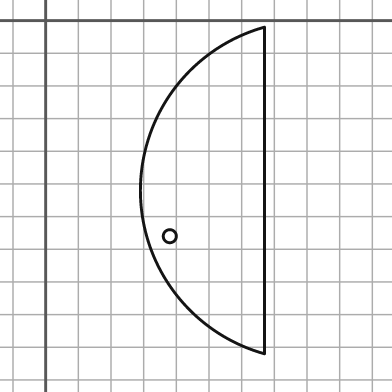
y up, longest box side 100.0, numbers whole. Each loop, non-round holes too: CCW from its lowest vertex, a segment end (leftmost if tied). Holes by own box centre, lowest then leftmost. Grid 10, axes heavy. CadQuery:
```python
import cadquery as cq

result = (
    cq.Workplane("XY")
    .moveTo(67.0, -102.0)
    .lineTo(67.0, -2.0)
    .threePointArc((29.0, -52.0), (67.0, -102.0))
    .close()
    .moveTo(38.0, -66.0)
    .circle(2.0)
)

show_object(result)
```